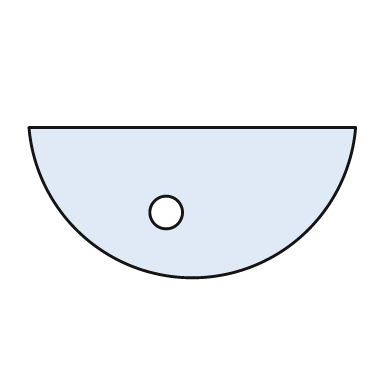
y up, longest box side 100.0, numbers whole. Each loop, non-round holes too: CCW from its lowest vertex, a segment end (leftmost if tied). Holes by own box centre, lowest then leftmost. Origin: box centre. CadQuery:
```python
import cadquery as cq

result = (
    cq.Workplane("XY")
    .moveTo(-50.0, 23.0)
    .threePointArc((0.0, -23.0), (50.0, 23.0))
    .close()
    .moveTo(-8.0, -3.0)
    .circle(5.0)
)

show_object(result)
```